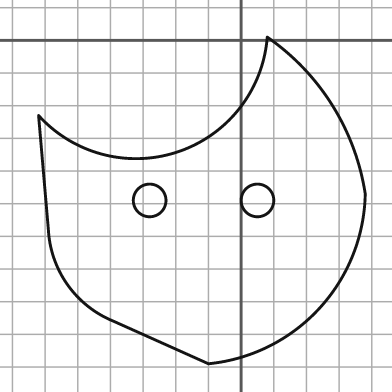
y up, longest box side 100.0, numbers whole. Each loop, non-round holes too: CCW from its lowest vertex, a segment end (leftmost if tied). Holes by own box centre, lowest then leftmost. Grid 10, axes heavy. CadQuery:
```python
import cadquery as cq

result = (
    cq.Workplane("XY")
    .moveTo(-10.0, -99.0)
    .threePointArc((24.0, -82.0), (38.0, -47.0))
    .threePointArc((28.0, -20.0), (8.0, 1.0))
    .threePointArc((-19.0, -34.0), (-62.0, -23.0))
    .lineTo(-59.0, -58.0)
    .threePointArc((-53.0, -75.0), (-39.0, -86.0))
    .close()
    .moveTo(-28.0, -49.0)
    .circle(5.0)
    .moveTo(5.0, -49.0)
    .circle(5.0)
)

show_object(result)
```